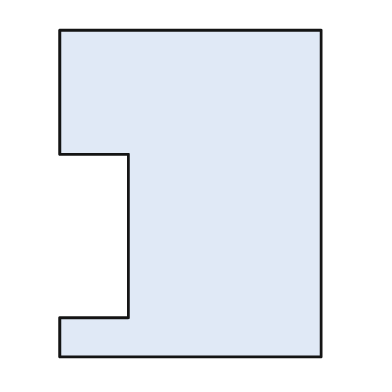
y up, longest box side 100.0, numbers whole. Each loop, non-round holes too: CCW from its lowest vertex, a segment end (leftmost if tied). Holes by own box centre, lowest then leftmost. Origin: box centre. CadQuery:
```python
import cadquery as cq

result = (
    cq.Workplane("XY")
    .moveTo(-40.0, -50.0)
    .lineTo(40.0, -50.0)
    .lineTo(40.0, 50.0)
    .lineTo(-40.0, 50.0)
    .lineTo(-40.0, 12.0)
    .lineTo(-19.0, 12.0)
    .lineTo(-19.0, -38.0)
    .lineTo(-40.0, -38.0)
    .close()
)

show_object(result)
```